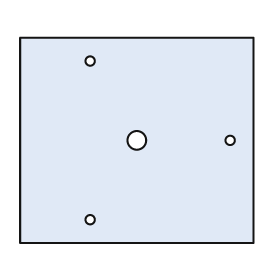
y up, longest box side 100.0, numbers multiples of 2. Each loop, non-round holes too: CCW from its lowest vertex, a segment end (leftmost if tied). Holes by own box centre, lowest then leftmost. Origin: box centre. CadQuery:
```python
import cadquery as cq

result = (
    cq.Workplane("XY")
    .moveTo(-50.0, -44.0)
    .lineTo(50.0, -44.0)
    .lineTo(50.0, 44.0)
    .lineTo(-50.0, 44.0)
    .close()
    .moveTo(-20.0, -34.0)
    .circle(2.0)
    .moveTo(0.0, 0.0)
    .circle(4.0)
    .moveTo(40.0, 0.0)
    .circle(2.0)
    .moveTo(-20.0, 34.0)
    .circle(2.0)
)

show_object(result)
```